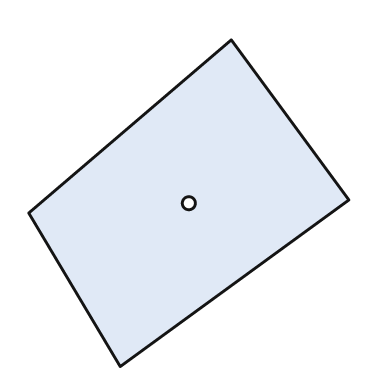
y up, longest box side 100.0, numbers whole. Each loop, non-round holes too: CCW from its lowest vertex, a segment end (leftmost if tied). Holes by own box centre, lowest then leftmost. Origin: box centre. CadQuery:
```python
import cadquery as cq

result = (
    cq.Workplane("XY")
    .moveTo(-21.0, -50.0)
    .lineTo(49.0, 1.0)
    .lineTo(13.0, 50.0)
    .lineTo(-49.0, -3.0)
    .close()
    .moveTo(0.0, 0.0)
    .circle(2.0)
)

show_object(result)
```